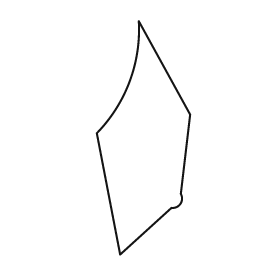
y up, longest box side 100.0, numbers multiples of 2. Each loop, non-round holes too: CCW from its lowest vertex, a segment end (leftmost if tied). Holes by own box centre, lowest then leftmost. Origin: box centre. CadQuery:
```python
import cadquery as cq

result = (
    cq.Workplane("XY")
    .moveTo(-10.0, -50.0)
    .lineTo(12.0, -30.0)
    .threePointArc((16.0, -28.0), (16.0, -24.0))
    .lineTo(20.0, 10.0)
    .lineTo(-2.0, 50.0)
    .threePointArc((-6.0, 24.0), (-20.0, 2.0))
    .close()
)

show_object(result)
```